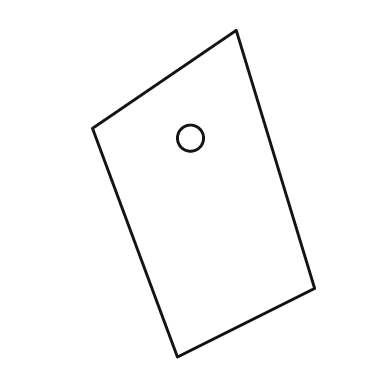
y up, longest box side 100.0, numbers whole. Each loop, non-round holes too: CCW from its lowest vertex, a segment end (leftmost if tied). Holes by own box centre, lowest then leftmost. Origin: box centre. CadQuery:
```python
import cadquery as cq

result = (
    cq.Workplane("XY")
    .moveTo(-8.0, -50.0)
    .lineTo(34.0, -29.0)
    .lineTo(10.0, 50.0)
    .lineTo(-34.0, 20.0)
    .close()
    .moveTo(-4.0, 17.0)
    .circle(4.0)
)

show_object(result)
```